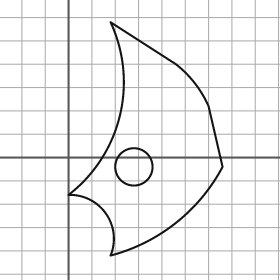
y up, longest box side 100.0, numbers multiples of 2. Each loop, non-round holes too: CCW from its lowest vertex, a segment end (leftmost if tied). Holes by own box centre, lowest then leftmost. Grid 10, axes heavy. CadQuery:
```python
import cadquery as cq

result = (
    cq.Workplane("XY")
    .moveTo(18.0, -42.0)
    .threePointArc((46.0, -28.0), (66.0, -4.0))
    .lineTo(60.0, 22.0)
    .threePointArc((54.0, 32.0), (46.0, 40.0))
    .lineTo(18.0, 58.0)
    .threePointArc((22.0, 18.0), (0.0, -16.0))
    .threePointArc((16.0, -24.0), (18.0, -42.0))
    .close()
    .moveTo(28.0, -4.0)
    .circle(8.0)
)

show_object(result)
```